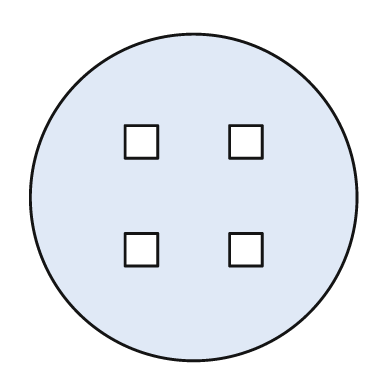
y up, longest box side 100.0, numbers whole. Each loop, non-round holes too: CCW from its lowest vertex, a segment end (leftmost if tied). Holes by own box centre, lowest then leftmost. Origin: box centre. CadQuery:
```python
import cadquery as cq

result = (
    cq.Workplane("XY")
    .moveTo(0.0, 0.0)
    .circle(50.0)
    .moveTo(-21.0, -21.0)
    .lineTo(-11.0, -21.0)
    .lineTo(-11.0, -11.0)
    .lineTo(-21.0, -11.0)
    .close()
    .moveTo(11.0, -21.0)
    .lineTo(21.0, -21.0)
    .lineTo(21.0, -11.0)
    .lineTo(11.0, -11.0)
    .close()
    .moveTo(-21.0, 12.0)
    .lineTo(-11.0, 12.0)
    .lineTo(-11.0, 22.0)
    .lineTo(-21.0, 22.0)
    .close()
    .moveTo(11.0, 12.0)
    .lineTo(21.0, 12.0)
    .lineTo(21.0, 22.0)
    .lineTo(11.0, 22.0)
    .close()
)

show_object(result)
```